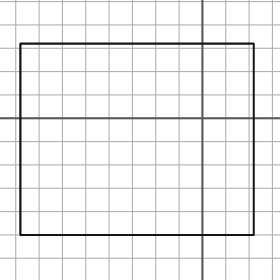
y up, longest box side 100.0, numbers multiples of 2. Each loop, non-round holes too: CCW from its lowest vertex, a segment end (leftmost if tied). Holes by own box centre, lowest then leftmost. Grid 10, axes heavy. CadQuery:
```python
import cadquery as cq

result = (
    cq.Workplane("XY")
    .moveTo(-78.0, -50.0)
    .lineTo(22.0, -50.0)
    .lineTo(22.0, 32.0)
    .lineTo(-78.0, 32.0)
    .close()
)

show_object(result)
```